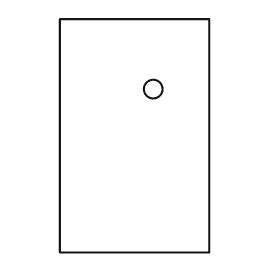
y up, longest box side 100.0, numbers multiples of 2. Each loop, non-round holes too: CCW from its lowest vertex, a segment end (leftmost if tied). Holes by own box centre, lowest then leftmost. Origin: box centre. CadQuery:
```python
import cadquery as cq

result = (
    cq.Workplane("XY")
    .moveTo(-32.0, -50.0)
    .lineTo(32.0, -50.0)
    .lineTo(32.0, 50.0)
    .lineTo(-32.0, 50.0)
    .close()
    .moveTo(8.0, 20.0)
    .circle(4.0)
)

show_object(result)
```